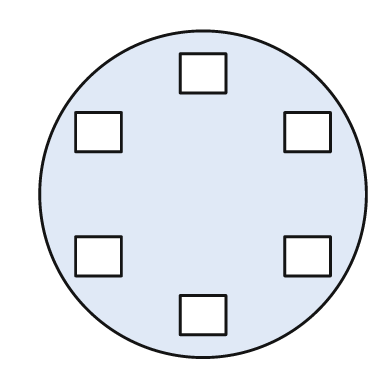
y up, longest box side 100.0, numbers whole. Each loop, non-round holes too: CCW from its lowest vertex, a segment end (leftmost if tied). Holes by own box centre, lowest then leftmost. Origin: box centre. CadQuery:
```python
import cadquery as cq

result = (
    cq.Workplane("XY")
    .moveTo(0.0, 0.0)
    .circle(50.0)
    .moveTo(-7.0, -43.0)
    .lineTo(7.0, -43.0)
    .lineTo(7.0, -31.0)
    .lineTo(-7.0, -31.0)
    .close()
    .moveTo(-39.0, -25.0)
    .lineTo(-25.0, -25.0)
    .lineTo(-25.0, -13.0)
    .lineTo(-39.0, -13.0)
    .close()
    .moveTo(25.0, -25.0)
    .lineTo(39.0, -25.0)
    .lineTo(39.0, -13.0)
    .lineTo(25.0, -13.0)
    .close()
    .moveTo(-39.0, 13.0)
    .lineTo(-25.0, 13.0)
    .lineTo(-25.0, 25.0)
    .lineTo(-39.0, 25.0)
    .close()
    .moveTo(25.0, 13.0)
    .lineTo(39.0, 13.0)
    .lineTo(39.0, 25.0)
    .lineTo(25.0, 25.0)
    .close()
    .moveTo(-7.0, 31.0)
    .lineTo(7.0, 31.0)
    .lineTo(7.0, 43.0)
    .lineTo(-7.0, 43.0)
    .close()
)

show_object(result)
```